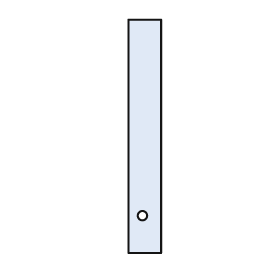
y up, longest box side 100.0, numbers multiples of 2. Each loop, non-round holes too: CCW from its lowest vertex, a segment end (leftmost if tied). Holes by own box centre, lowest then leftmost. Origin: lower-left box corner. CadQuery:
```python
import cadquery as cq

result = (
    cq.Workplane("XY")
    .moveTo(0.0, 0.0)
    .lineTo(14.0, 0.0)
    .lineTo(14.0, 100.0)
    .lineTo(0.0, 100.0)
    .close()
    .moveTo(6.0, 16.0)
    .circle(2.0)
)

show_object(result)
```